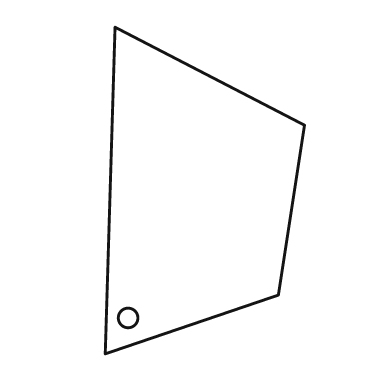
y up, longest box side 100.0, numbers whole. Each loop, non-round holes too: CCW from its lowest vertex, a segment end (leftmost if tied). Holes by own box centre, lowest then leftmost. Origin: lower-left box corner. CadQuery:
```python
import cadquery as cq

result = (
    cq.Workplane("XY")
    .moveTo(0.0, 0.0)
    .lineTo(53.0, 18.0)
    .lineTo(61.0, 70.0)
    .lineTo(3.0, 100.0)
    .close()
    .moveTo(7.0, 11.0)
    .circle(3.0)
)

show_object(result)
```